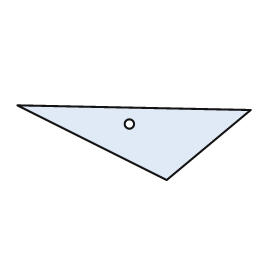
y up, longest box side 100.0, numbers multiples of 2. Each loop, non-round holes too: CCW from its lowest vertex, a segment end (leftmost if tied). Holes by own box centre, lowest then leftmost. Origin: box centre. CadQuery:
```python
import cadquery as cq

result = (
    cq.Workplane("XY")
    .moveTo(14.0, -16.0)
    .lineTo(50.0, 14.0)
    .lineTo(-50.0, 16.0)
    .close()
    .moveTo(-2.0, 8.0)
    .circle(2.0)
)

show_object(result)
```